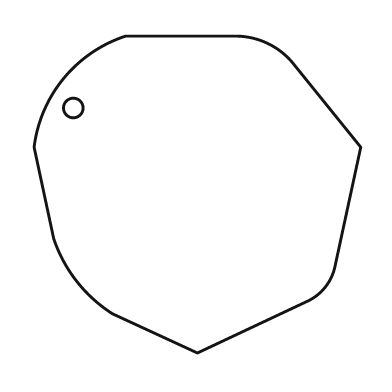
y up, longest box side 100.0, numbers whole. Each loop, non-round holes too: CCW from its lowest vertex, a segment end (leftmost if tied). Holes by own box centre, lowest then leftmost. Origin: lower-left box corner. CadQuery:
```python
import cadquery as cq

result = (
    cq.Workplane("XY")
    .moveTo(50.0, 0.0)
    .lineTo(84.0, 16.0)
    .threePointArc((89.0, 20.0), (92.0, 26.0))
    .lineTo(100.0, 63.0)
    .lineTo(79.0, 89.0)
    .threePointArc((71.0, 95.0), (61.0, 97.0))
    .lineTo(28.0, 97.0)
    .threePointArc((9.0, 84.0), (0.0, 63.0))
    .lineTo(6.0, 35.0)
    .threePointArc((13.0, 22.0), (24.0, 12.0))
    .close()
    .moveTo(12.0, 75.0)
    .circle(3.0)
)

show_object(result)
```